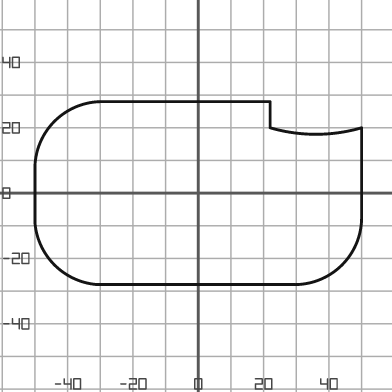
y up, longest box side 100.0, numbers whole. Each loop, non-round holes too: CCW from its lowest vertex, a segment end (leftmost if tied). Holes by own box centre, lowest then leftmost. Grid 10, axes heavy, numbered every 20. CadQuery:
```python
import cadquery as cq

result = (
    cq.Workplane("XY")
    .moveTo(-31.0, -28.0)
    .lineTo(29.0, -28.0)
    .threePointArc((44.0, -22.0), (50.0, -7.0))
    .lineTo(50.0, 20.0)
    .threePointArc((36.0, 18.0), (22.0, 20.0))
    .lineTo(22.0, 28.0)
    .lineTo(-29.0, 28.0)
    .threePointArc((-44.0, 22.0), (-50.0, 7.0))
    .lineTo(-50.0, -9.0)
    .threePointArc((-44.0, -22.0), (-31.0, -28.0))
    .close()
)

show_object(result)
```